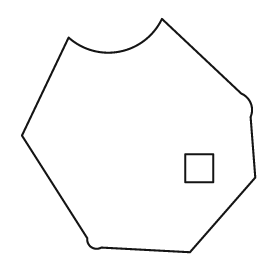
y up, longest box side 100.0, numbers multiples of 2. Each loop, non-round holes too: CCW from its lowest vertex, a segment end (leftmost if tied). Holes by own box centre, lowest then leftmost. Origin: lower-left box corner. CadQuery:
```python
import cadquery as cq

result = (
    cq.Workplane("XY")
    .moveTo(72.0, 0.0)
    .lineTo(100.0, 32.0)
    .lineTo(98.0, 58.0)
    .threePointArc((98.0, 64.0), (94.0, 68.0))
    .lineTo(60.0, 100.0)
    .threePointArc((42.0, 86.0), (20.0, 92.0))
    .lineTo(0.0, 50.0)
    .lineTo(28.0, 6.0)
    .threePointArc((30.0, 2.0), (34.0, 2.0))
    .close()
    .moveTo(70.0, 30.0)
    .lineTo(82.0, 30.0)
    .lineTo(82.0, 42.0)
    .lineTo(70.0, 42.0)
    .close()
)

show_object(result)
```